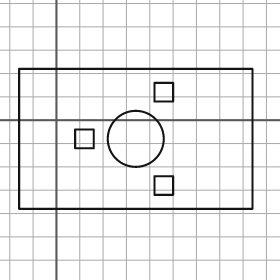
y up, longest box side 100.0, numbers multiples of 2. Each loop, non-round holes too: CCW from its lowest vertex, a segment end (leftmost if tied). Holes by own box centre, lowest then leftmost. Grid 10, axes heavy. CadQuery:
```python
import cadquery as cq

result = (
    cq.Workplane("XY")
    .moveTo(-16.0, -38.0)
    .lineTo(84.0, -38.0)
    .lineTo(84.0, 22.0)
    .lineTo(-16.0, 22.0)
    .close()
    .moveTo(42.0, -32.0)
    .lineTo(50.0, -32.0)
    .lineTo(50.0, -24.0)
    .lineTo(42.0, -24.0)
    .close()
    .moveTo(8.0, -12.0)
    .lineTo(16.0, -12.0)
    .lineTo(16.0, -4.0)
    .lineTo(8.0, -4.0)
    .close()
    .moveTo(34.0, -8.0)
    .circle(12.0)
    .moveTo(42.0, 8.0)
    .lineTo(50.0, 8.0)
    .lineTo(50.0, 16.0)
    .lineTo(42.0, 16.0)
    .close()
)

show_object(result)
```